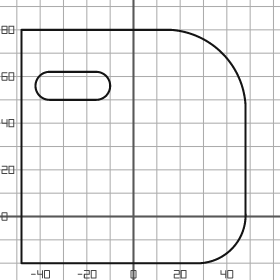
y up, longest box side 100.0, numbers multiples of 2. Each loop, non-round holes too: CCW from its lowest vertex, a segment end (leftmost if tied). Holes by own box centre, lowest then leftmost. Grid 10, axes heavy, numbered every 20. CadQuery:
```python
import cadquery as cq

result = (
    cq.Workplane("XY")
    .moveTo(-48.0, -20.0)
    .lineTo(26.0, -20.0)
    .threePointArc((42.0, -14.0), (48.0, 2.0))
    .lineTo(48.0, 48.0)
    .threePointArc((38.0, 70.0), (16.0, 80.0))
    .lineTo(-48.0, 80.0)
    .close()
    .moveTo(-36.0, 50.0)
    .lineTo(-16.0, 50.0)
    .threePointArc((-10.0, 56.0), (-16.0, 62.0))
    .lineTo(-36.0, 62.0)
    .threePointArc((-42.0, 56.0), (-36.0, 50.0))
    .close()
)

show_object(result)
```